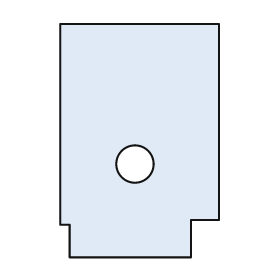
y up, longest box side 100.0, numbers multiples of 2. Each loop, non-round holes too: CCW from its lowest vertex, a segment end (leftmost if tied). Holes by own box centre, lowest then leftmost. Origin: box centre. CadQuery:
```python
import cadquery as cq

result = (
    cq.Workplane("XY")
    .moveTo(-30.0, -50.0)
    .lineTo(22.0, -50.0)
    .lineTo(22.0, -34.0)
    .lineTo(34.0, -34.0)
    .lineTo(34.0, 50.0)
    .lineTo(-34.0, 50.0)
    .lineTo(-34.0, -36.0)
    .lineTo(-30.0, -36.0)
    .close()
    .moveTo(-2.0, -10.0)
    .circle(8.0)
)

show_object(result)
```